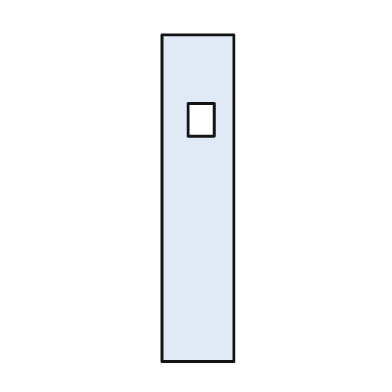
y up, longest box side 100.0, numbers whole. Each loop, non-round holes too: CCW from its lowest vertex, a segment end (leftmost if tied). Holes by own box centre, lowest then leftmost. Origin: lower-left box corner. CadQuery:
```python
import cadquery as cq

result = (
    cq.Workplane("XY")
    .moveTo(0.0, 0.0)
    .lineTo(22.0, 0.0)
    .lineTo(22.0, 100.0)
    .lineTo(0.0, 100.0)
    .close()
    .moveTo(8.0, 69.0)
    .lineTo(16.0, 69.0)
    .lineTo(16.0, 79.0)
    .lineTo(8.0, 79.0)
    .close()
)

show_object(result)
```